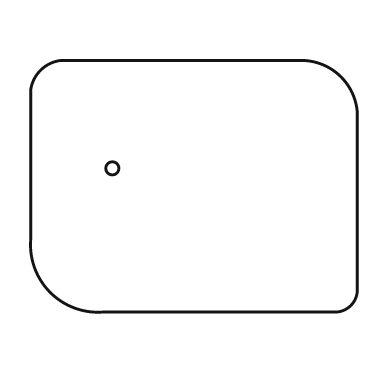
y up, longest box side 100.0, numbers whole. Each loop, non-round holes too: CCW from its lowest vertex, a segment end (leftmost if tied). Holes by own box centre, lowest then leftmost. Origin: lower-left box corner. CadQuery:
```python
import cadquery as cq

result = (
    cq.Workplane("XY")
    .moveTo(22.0, 0.0)
    .lineTo(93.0, 0.0)
    .threePointArc((98.0, 2.0), (100.0, 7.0))
    .lineTo(100.0, 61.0)
    .threePointArc((95.0, 72.0), (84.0, 77.0))
    .lineTo(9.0, 77.0)
    .threePointArc((3.0, 74.0), (0.0, 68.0))
    .lineTo(0.0, 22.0)
    .threePointArc((6.0, 6.0), (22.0, 0.0))
    .close()
    .moveTo(25.0, 44.0)
    .circle(2.0)
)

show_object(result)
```